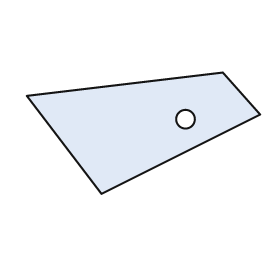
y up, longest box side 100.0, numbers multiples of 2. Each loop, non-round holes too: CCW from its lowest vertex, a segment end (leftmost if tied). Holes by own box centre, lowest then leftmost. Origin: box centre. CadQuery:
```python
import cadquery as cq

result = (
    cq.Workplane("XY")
    .moveTo(-18.0, -26.0)
    .lineTo(50.0, 8.0)
    .lineTo(34.0, 26.0)
    .lineTo(-50.0, 16.0)
    .close()
    .moveTo(18.0, 6.0)
    .circle(4.0)
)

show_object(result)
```